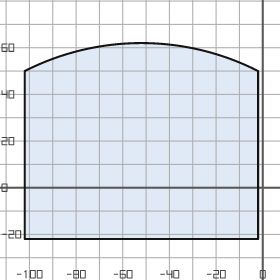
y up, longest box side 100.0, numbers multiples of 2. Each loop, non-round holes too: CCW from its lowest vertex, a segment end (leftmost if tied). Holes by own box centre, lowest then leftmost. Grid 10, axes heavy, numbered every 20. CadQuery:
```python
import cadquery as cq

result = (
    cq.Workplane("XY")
    .moveTo(-102.0, -22.0)
    .lineTo(-2.0, -22.0)
    .lineTo(-2.0, 50.0)
    .threePointArc((-52.0, 62.0), (-102.0, 50.0))
    .close()
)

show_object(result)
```